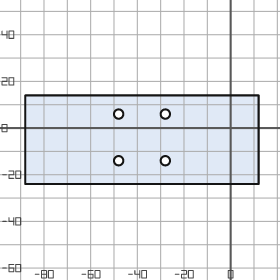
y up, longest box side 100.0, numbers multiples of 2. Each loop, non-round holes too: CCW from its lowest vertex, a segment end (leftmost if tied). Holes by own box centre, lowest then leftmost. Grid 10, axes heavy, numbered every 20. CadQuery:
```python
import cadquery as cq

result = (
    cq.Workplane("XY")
    .moveTo(-88.0, -24.0)
    .lineTo(12.0, -24.0)
    .lineTo(12.0, 14.0)
    .lineTo(-88.0, 14.0)
    .close()
    .moveTo(-48.0, -14.0)
    .circle(2.0)
    .moveTo(-28.0, -14.0)
    .circle(2.0)
    .moveTo(-48.0, 6.0)
    .circle(2.0)
    .moveTo(-28.0, 6.0)
    .circle(2.0)
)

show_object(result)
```